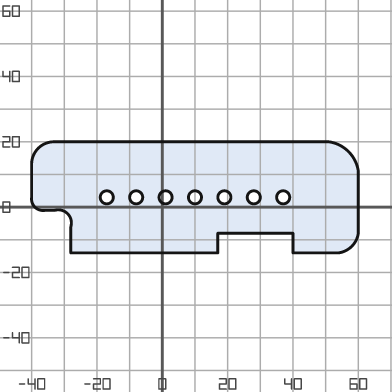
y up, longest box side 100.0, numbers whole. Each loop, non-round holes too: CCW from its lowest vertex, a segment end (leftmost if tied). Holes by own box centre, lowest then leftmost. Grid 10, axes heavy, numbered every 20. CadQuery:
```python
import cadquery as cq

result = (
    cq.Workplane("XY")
    .moveTo(-28.0, -14.0)
    .lineTo(17.0, -14.0)
    .lineTo(17.0, -8.0)
    .lineTo(40.0, -8.0)
    .lineTo(40.0, -14.0)
    .lineTo(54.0, -14.0)
    .threePointArc((58.0, -12.0), (60.0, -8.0))
    .lineTo(60.0, 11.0)
    .threePointArc((57.0, 17.0), (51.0, 20.0))
    .lineTo(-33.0, 20.0)
    .threePointArc((-38.0, 18.0), (-40.0, 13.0))
    .lineTo(-40.0, 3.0)
    .threePointArc((-39.0, 0.0), (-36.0, -1.0))
    .lineTo(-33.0, -1.0)
    .threePointArc((-29.0, -2.0), (-28.0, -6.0))
    .close()
    .moveTo(-17.0, 3.0)
    .circle(2.0)
    .moveTo(-8.0, 3.0)
    .circle(2.0)
    .moveTo(1.0, 3.0)
    .circle(2.0)
    .moveTo(10.0, 3.0)
    .circle(2.0)
    .moveTo(19.0, 3.0)
    .circle(2.0)
    .moveTo(28.0, 3.0)
    .circle(2.0)
    .moveTo(37.0, 3.0)
    .circle(2.0)
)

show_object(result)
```